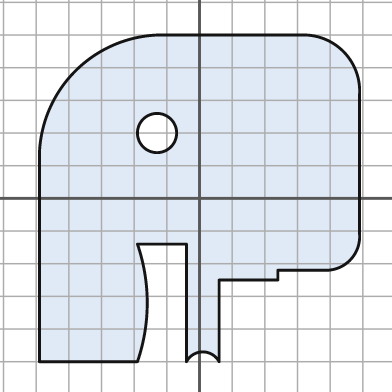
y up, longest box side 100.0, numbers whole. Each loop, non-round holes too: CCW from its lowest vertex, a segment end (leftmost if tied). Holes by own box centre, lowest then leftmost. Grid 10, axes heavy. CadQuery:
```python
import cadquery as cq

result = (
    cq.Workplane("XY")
    .moveTo(-49.0, -50.0)
    .lineTo(-19.0, -50.0)
    .threePointArc((-16.0, -32.0), (-19.0, -14.0))
    .lineTo(-4.0, -14.0)
    .lineTo(-4.0, -50.0)
    .threePointArc((1.0, -47.0), (6.0, -50.0))
    .lineTo(6.0, -25.0)
    .lineTo(24.0, -25.0)
    .lineTo(24.0, -22.0)
    .lineTo(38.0, -22.0)
    .threePointArc((46.0, -19.0), (49.0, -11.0))
    .lineTo(49.0, 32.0)
    .threePointArc((44.0, 45.0), (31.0, 50.0))
    .lineTo(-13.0, 50.0)
    .threePointArc((-38.0, 39.0), (-49.0, 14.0))
    .close()
    .moveTo(-13.0, 20.0)
    .circle(6.0)
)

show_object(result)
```